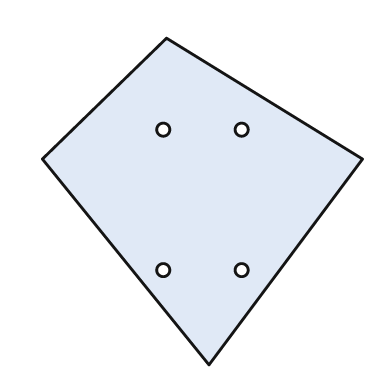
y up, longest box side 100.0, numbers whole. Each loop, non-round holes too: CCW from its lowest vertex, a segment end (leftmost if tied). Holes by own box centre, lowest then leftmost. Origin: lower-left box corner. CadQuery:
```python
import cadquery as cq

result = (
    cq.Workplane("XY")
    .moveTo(51.0, 0.0)
    .lineTo(98.0, 63.0)
    .lineTo(38.0, 100.0)
    .lineTo(0.0, 63.0)
    .close()
    .moveTo(37.0, 29.0)
    .circle(2.0)
    .moveTo(61.0, 29.0)
    .circle(2.0)
    .moveTo(37.0, 72.0)
    .circle(2.0)
    .moveTo(61.0, 72.0)
    .circle(2.0)
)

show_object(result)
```